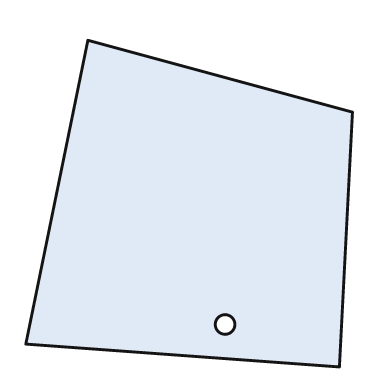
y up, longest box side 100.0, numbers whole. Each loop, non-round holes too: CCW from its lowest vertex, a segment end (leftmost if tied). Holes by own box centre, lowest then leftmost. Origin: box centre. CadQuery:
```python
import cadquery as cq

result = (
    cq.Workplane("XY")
    .moveTo(46.0, -50.0)
    .lineTo(50.0, 28.0)
    .lineTo(-31.0, 50.0)
    .lineTo(-50.0, -43.0)
    .close()
    .moveTo(11.0, -37.0)
    .circle(3.0)
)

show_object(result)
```